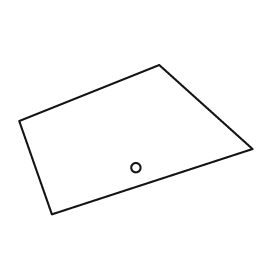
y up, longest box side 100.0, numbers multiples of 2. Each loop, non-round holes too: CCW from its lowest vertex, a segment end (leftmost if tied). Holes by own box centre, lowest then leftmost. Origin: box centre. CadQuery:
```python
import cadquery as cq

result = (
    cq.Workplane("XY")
    .moveTo(-36.0, -32.0)
    .lineTo(50.0, -4.0)
    .lineTo(10.0, 32.0)
    .lineTo(-50.0, 8.0)
    .close()
    .moveTo(0.0, -12.0)
    .circle(2.0)
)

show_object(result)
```